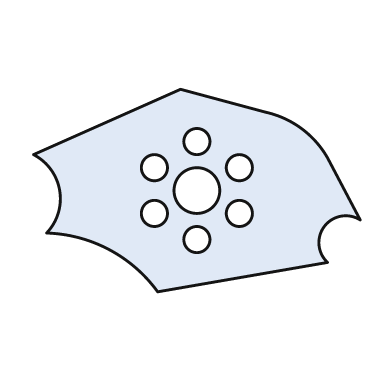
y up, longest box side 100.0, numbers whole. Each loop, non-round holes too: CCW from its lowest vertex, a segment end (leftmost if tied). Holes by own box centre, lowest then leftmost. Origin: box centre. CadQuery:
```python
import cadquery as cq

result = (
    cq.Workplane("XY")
    .moveTo(-12.0, -31.0)
    .lineTo(40.0, -22.0)
    .threePointArc((39.0, -11.0), (50.0, -9.0))
    .lineTo(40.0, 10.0)
    .threePointArc((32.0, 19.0), (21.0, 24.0))
    .lineTo(-5.0, 31.0)
    .lineTo(-50.0, 11.0)
    .threePointArc((-42.0, 0.0), (-46.0, -13.0))
    .threePointArc((-27.0, -18.0), (-12.0, -31.0))
    .close()
    .moveTo(0.0, -15.0)
    .circle(4.0)
    .moveTo(-13.0, -7.0)
    .circle(4.0)
    .moveTo(13.0, -7.0)
    .circle(4.0)
    .moveTo(0.0, 0.0)
    .circle(7.0)
    .moveTo(-13.0, 7.0)
    .circle(4.0)
    .moveTo(13.0, 7.0)
    .circle(4.0)
    .moveTo(0.0, 15.0)
    .circle(4.0)
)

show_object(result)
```